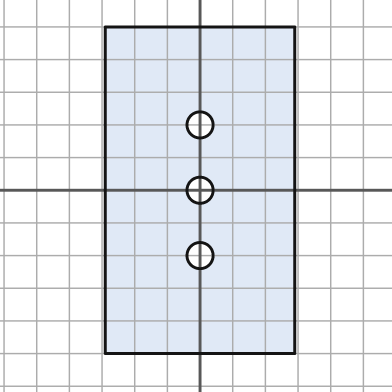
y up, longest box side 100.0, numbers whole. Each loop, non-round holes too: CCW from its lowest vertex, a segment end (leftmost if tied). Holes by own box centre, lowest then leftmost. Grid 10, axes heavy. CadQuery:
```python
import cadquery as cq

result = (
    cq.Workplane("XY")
    .moveTo(-29.0, -50.0)
    .lineTo(29.0, -50.0)
    .lineTo(29.0, 50.0)
    .lineTo(-29.0, 50.0)
    .close()
    .moveTo(0.0, -20.0)
    .circle(4.0)
    .moveTo(0.0, 0.0)
    .circle(4.0)
    .moveTo(0.0, 20.0)
    .circle(4.0)
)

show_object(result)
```